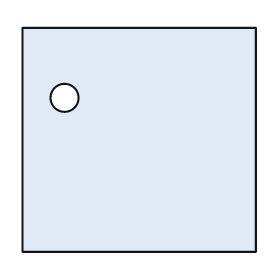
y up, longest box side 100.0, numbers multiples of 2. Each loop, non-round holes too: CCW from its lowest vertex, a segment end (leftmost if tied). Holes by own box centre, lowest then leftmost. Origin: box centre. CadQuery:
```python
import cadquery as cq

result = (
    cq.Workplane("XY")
    .moveTo(-50.0, -48.0)
    .lineTo(50.0, -48.0)
    .lineTo(50.0, 48.0)
    .lineTo(-50.0, 48.0)
    .close()
    .moveTo(-32.0, 18.0)
    .circle(6.0)
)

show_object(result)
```